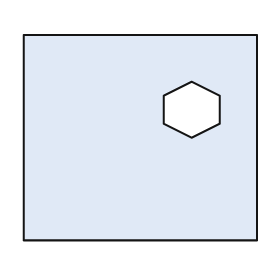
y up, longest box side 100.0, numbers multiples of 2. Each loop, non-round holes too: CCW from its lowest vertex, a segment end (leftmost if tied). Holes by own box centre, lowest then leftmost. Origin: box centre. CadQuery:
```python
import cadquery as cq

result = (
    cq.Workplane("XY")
    .moveTo(-50.0, -44.0)
    .lineTo(50.0, -44.0)
    .lineTo(50.0, 44.0)
    .lineTo(-50.0, 44.0)
    .close()
    .moveTo(22.0, 0.0)
    .lineTo(34.0, 6.0)
    .lineTo(34.0, 18.0)
    .lineTo(22.0, 24.0)
    .lineTo(10.0, 18.0)
    .lineTo(10.0, 6.0)
    .close()
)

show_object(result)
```